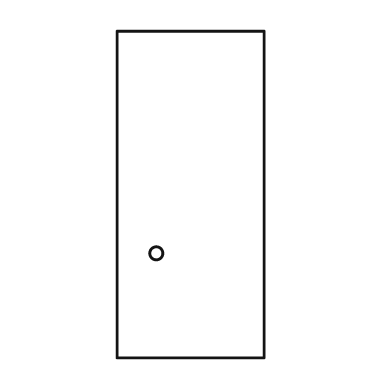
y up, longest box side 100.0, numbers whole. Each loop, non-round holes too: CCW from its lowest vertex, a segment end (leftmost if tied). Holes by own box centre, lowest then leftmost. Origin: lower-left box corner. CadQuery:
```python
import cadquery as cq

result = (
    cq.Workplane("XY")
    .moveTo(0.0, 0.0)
    .lineTo(45.0, 0.0)
    .lineTo(45.0, 100.0)
    .lineTo(0.0, 100.0)
    .close()
    .moveTo(12.0, 32.0)
    .circle(2.0)
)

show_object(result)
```